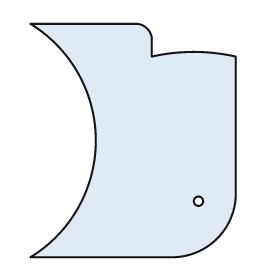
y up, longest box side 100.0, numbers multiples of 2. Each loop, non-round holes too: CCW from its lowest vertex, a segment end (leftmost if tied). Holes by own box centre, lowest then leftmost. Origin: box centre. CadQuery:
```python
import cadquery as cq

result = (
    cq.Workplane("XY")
    .moveTo(-44.0, -50.0)
    .lineTo(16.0, -50.0)
    .threePointArc((36.0, -42.0), (44.0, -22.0))
    .lineTo(44.0, 36.0)
    .threePointArc((26.0, 38.0), (8.0, 36.0))
    .lineTo(8.0, 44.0)
    .threePointArc((6.0, 48.0), (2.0, 50.0))
    .lineTo(-44.0, 50.0)
    .threePointArc((-16.0, 0.0), (-44.0, -50.0))
    .close()
    .moveTo(28.0, -26.0)
    .circle(2.0)
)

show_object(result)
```